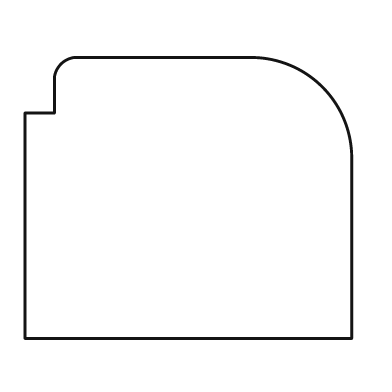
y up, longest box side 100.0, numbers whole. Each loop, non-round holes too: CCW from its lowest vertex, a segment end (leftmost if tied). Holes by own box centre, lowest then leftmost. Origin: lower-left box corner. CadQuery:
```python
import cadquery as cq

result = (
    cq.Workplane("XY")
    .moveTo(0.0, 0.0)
    .lineTo(100.0, 0.0)
    .lineTo(100.0, 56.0)
    .threePointArc((91.0, 77.0), (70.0, 86.0))
    .lineTo(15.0, 86.0)
    .threePointArc((11.0, 84.0), (9.0, 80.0))
    .lineTo(9.0, 69.0)
    .lineTo(0.0, 69.0)
    .close()
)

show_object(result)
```